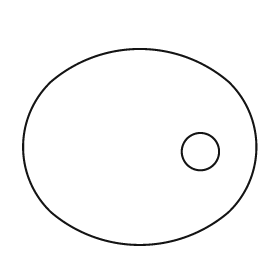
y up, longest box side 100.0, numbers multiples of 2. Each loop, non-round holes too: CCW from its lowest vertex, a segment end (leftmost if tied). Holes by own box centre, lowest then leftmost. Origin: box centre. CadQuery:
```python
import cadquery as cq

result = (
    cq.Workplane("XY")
    .moveTo(-38.0, -28.0)
    .threePointArc((0.0, -42.0), (38.0, -28.0))
    .threePointArc((50.0, 0.0), (38.0, 28.0))
    .threePointArc((0.0, 42.0), (-38.0, 28.0))
    .threePointArc((-50.0, 0.0), (-38.0, -28.0))
    .close()
    .moveTo(26.0, -2.0)
    .circle(8.0)
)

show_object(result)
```